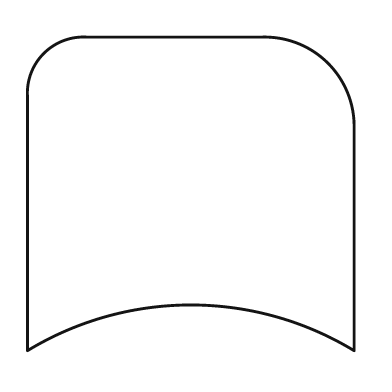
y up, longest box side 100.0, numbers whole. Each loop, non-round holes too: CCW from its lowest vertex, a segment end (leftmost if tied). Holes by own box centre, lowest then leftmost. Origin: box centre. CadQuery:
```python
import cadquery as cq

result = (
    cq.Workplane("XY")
    .moveTo(-50.0, -48.0)
    .threePointArc((0.0, -34.0), (50.0, -48.0))
    .lineTo(50.0, 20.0)
    .threePointArc((42.0, 40.0), (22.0, 48.0))
    .lineTo(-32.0, 48.0)
    .threePointArc((-45.0, 43.0), (-50.0, 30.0))
    .close()
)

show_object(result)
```